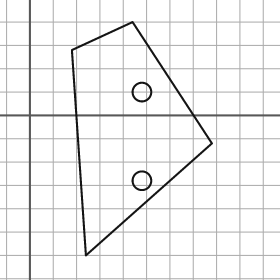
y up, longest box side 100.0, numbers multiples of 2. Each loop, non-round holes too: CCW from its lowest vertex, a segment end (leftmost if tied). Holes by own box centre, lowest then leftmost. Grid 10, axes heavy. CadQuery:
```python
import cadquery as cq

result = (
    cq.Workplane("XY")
    .moveTo(24.0, -60.0)
    .lineTo(78.0, -12.0)
    .lineTo(44.0, 40.0)
    .lineTo(18.0, 28.0)
    .close()
    .moveTo(48.0, -28.0)
    .circle(4.0)
    .moveTo(48.0, 10.0)
    .circle(4.0)
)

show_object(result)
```